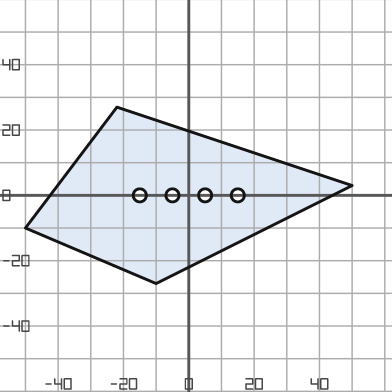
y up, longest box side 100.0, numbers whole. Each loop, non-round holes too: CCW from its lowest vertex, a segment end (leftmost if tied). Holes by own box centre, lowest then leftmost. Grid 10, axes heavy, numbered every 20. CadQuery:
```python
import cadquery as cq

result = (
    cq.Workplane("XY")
    .moveTo(-10.0, -27.0)
    .lineTo(50.0, 3.0)
    .lineTo(-22.0, 27.0)
    .lineTo(-50.0, -10.0)
    .close()
    .moveTo(-15.0, 0.0)
    .circle(2.0)
    .moveTo(-5.0, 0.0)
    .circle(2.0)
    .moveTo(5.0, 0.0)
    .circle(2.0)
    .moveTo(15.0, 0.0)
    .circle(2.0)
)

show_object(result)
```